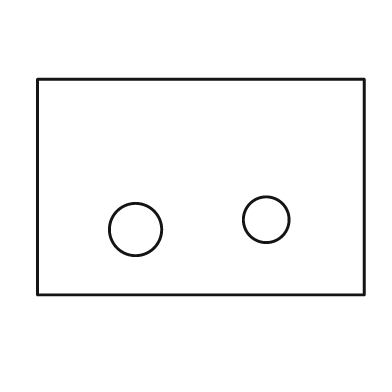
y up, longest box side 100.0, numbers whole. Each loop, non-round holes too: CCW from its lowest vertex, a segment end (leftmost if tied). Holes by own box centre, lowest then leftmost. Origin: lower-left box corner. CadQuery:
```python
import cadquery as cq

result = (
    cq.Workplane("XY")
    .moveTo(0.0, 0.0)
    .lineTo(100.0, 0.0)
    .lineTo(100.0, 66.0)
    .lineTo(0.0, 66.0)
    .close()
    .moveTo(30.0, 20.0)
    .circle(8.0)
    .moveTo(70.0, 23.0)
    .circle(7.0)
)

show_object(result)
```